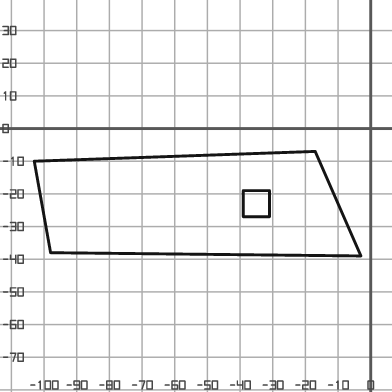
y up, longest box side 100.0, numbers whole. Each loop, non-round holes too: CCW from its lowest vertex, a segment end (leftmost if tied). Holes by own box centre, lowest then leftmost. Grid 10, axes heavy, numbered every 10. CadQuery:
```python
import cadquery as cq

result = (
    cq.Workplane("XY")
    .moveTo(-3.0, -39.0)
    .lineTo(-17.0, -7.0)
    .lineTo(-103.0, -10.0)
    .lineTo(-98.0, -38.0)
    .close()
    .moveTo(-39.0, -27.0)
    .lineTo(-31.0, -27.0)
    .lineTo(-31.0, -19.0)
    .lineTo(-39.0, -19.0)
    .close()
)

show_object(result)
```